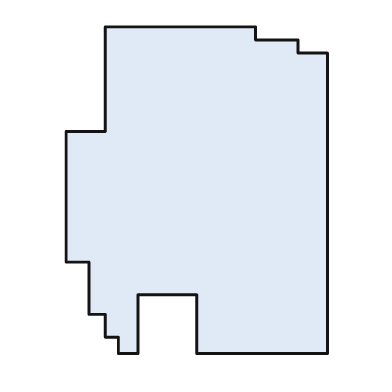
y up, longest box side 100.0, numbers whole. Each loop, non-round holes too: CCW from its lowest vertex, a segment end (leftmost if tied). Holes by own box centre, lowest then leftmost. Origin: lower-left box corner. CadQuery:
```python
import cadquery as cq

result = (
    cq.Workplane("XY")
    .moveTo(16.0, 0.0)
    .lineTo(22.0, 0.0)
    .lineTo(22.0, 18.0)
    .lineTo(40.0, 18.0)
    .lineTo(40.0, 0.0)
    .lineTo(80.0, 0.0)
    .lineTo(80.0, 92.0)
    .lineTo(71.0, 92.0)
    .lineTo(71.0, 96.0)
    .lineTo(58.0, 96.0)
    .lineTo(58.0, 100.0)
    .lineTo(12.0, 100.0)
    .lineTo(12.0, 68.0)
    .lineTo(0.0, 68.0)
    .lineTo(0.0, 28.0)
    .lineTo(7.0, 28.0)
    .lineTo(7.0, 12.0)
    .lineTo(12.0, 12.0)
    .lineTo(12.0, 5.0)
    .lineTo(16.0, 5.0)
    .close()
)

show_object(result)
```